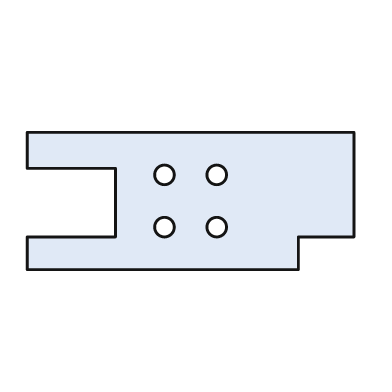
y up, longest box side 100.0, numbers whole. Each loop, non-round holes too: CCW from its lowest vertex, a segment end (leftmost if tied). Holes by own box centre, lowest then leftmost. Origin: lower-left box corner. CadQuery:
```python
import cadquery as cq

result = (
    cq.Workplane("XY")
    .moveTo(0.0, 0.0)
    .lineTo(83.0, 0.0)
    .lineTo(83.0, 10.0)
    .lineTo(100.0, 10.0)
    .lineTo(100.0, 42.0)
    .lineTo(0.0, 42.0)
    .lineTo(0.0, 31.0)
    .lineTo(27.0, 31.0)
    .lineTo(27.0, 10.0)
    .lineTo(0.0, 10.0)
    .close()
    .moveTo(42.0, 13.0)
    .circle(3.0)
    .moveTo(58.0, 13.0)
    .circle(3.0)
    .moveTo(42.0, 29.0)
    .circle(3.0)
    .moveTo(58.0, 29.0)
    .circle(3.0)
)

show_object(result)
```